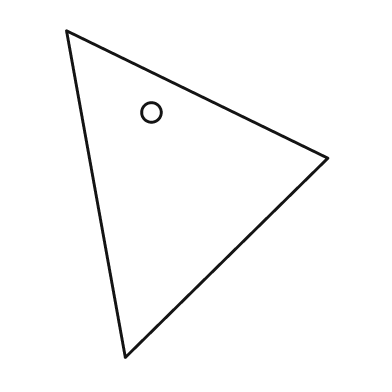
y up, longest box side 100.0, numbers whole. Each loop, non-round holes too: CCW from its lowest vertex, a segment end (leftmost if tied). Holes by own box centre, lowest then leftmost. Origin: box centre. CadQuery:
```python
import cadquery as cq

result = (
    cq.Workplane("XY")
    .moveTo(-22.0, -50.0)
    .lineTo(40.0, 11.0)
    .lineTo(-40.0, 50.0)
    .close()
    .moveTo(-14.0, 25.0)
    .circle(3.0)
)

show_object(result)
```